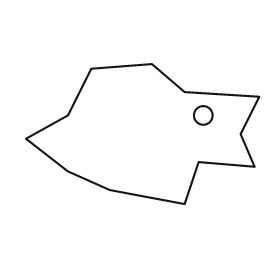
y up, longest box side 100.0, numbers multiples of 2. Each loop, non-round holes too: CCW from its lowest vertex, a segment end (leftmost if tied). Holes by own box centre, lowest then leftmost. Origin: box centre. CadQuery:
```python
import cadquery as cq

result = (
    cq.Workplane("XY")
    .moveTo(18.0, -30.0)
    .lineTo(24.0, -12.0)
    .lineTo(48.0, -14.0)
    .lineTo(42.0, 0.0)
    .lineTo(50.0, 16.0)
    .lineTo(18.0, 18.0)
    .lineTo(4.0, 30.0)
    .lineTo(-22.0, 28.0)
    .lineTo(-32.0, 8.0)
    .lineTo(-50.0, -2.0)
    .lineTo(-32.0, -16.0)
    .lineTo(-14.0, -24.0)
    .close()
    .moveTo(26.0, 8.0)
    .circle(4.0)
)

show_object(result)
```